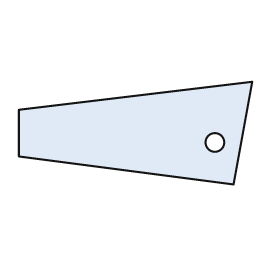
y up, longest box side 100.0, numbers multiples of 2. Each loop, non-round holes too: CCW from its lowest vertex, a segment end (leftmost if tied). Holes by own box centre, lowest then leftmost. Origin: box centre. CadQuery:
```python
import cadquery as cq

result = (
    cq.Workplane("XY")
    .moveTo(42.0, -22.0)
    .lineTo(50.0, 22.0)
    .lineTo(-50.0, 10.0)
    .lineTo(-50.0, -10.0)
    .close()
    .moveTo(34.0, -4.0)
    .circle(4.0)
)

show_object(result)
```